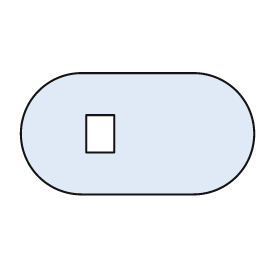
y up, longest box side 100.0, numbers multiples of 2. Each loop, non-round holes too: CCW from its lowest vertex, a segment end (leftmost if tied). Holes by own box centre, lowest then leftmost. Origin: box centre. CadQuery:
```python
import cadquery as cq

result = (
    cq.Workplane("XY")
    .moveTo(-24.0, -26.0)
    .lineTo(24.0, -26.0)
    .threePointArc((50.0, 0.0), (24.0, 26.0))
    .lineTo(-24.0, 26.0)
    .threePointArc((-50.0, 0.0), (-24.0, -26.0))
    .close()
    .moveTo(-22.0, -8.0)
    .lineTo(-10.0, -8.0)
    .lineTo(-10.0, 8.0)
    .lineTo(-22.0, 8.0)
    .close()
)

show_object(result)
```